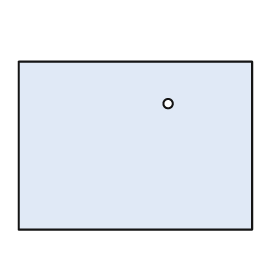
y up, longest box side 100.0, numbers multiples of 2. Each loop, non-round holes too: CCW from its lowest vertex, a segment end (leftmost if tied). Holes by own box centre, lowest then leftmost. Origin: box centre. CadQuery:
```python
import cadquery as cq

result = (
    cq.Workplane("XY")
    .moveTo(-50.0, -36.0)
    .lineTo(50.0, -36.0)
    .lineTo(50.0, 36.0)
    .lineTo(-50.0, 36.0)
    .close()
    .moveTo(14.0, 18.0)
    .circle(2.0)
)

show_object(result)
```